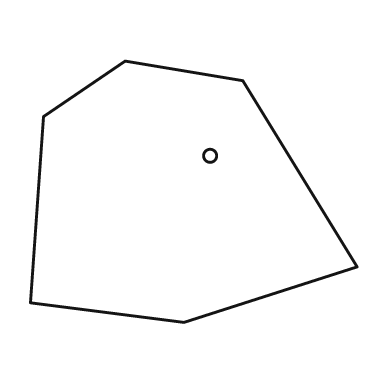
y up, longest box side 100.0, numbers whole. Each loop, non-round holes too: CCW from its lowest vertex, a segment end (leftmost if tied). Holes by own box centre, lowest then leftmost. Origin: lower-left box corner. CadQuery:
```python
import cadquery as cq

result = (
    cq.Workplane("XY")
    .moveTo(47.0, 0.0)
    .lineTo(100.0, 17.0)
    .lineTo(65.0, 74.0)
    .lineTo(29.0, 80.0)
    .lineTo(4.0, 63.0)
    .lineTo(0.0, 6.0)
    .close()
    .moveTo(55.0, 51.0)
    .circle(2.0)
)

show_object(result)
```